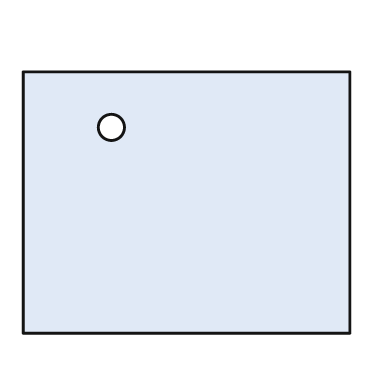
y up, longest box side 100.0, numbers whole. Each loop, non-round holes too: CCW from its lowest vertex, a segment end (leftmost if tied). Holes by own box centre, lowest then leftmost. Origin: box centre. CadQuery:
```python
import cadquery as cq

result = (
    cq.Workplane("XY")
    .moveTo(-50.0, -40.0)
    .lineTo(50.0, -40.0)
    .lineTo(50.0, 40.0)
    .lineTo(-50.0, 40.0)
    .close()
    .moveTo(-23.0, 23.0)
    .circle(4.0)
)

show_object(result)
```